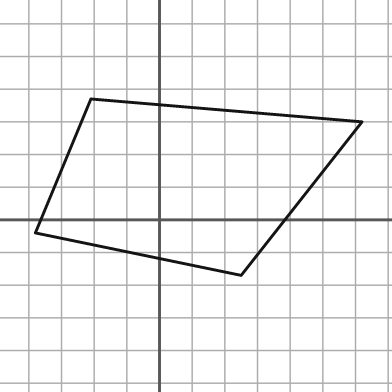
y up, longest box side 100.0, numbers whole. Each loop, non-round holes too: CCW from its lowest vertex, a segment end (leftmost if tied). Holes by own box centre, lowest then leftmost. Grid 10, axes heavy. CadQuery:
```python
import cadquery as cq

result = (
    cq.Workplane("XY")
    .moveTo(25.0, -17.0)
    .lineTo(62.0, 30.0)
    .lineTo(-21.0, 37.0)
    .lineTo(-38.0, -4.0)
    .close()
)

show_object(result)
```